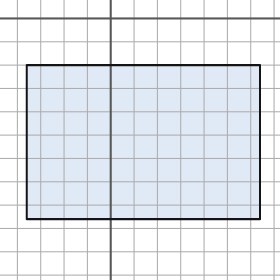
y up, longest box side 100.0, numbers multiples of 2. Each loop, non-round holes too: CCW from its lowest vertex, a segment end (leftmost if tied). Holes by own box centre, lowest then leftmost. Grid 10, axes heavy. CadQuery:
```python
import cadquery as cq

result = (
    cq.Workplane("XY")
    .moveTo(-36.0, -86.0)
    .lineTo(64.0, -86.0)
    .lineTo(64.0, -20.0)
    .lineTo(-36.0, -20.0)
    .close()
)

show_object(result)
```